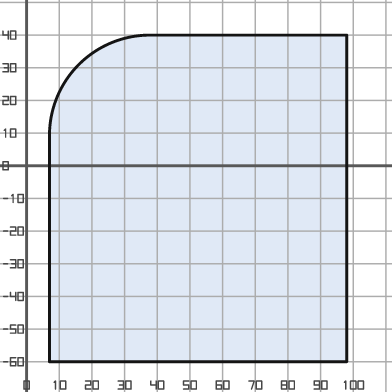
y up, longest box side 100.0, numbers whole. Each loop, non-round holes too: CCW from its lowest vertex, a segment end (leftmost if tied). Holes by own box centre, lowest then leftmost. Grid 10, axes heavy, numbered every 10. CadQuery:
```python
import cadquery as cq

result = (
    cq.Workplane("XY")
    .moveTo(7.0, -60.0)
    .lineTo(98.0, -60.0)
    .lineTo(98.0, 40.0)
    .lineTo(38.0, 40.0)
    .threePointArc((16.0, 31.0), (7.0, 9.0))
    .close()
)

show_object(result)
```